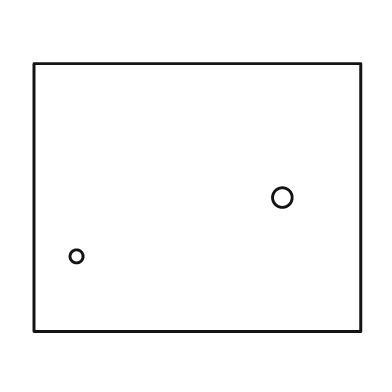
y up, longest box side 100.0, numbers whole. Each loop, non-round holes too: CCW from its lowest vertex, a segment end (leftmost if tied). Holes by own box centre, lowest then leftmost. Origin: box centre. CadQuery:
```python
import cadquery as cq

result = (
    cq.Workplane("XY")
    .moveTo(-50.0, -41.0)
    .lineTo(50.0, -41.0)
    .lineTo(50.0, 41.0)
    .lineTo(-50.0, 41.0)
    .close()
    .moveTo(-37.0, -18.0)
    .circle(2.0)
    .moveTo(26.0, 0.0)
    .circle(3.0)
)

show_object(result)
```